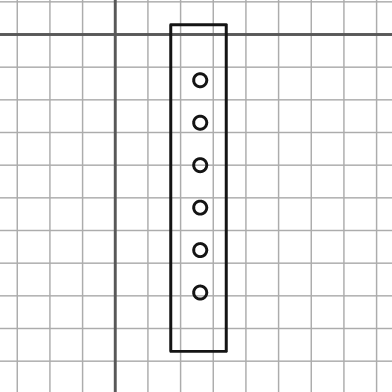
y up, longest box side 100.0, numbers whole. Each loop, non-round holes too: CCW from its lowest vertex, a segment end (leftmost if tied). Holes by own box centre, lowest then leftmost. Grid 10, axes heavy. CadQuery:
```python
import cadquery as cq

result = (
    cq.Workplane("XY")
    .moveTo(17.0, -97.0)
    .lineTo(34.0, -97.0)
    .lineTo(34.0, 3.0)
    .lineTo(17.0, 3.0)
    .close()
    .moveTo(26.0, -79.0)
    .circle(2.0)
    .moveTo(26.0, -66.0)
    .circle(2.0)
    .moveTo(26.0, -53.0)
    .circle(2.0)
    .moveTo(26.0, -40.0)
    .circle(2.0)
    .moveTo(26.0, -27.0)
    .circle(2.0)
    .moveTo(26.0, -14.0)
    .circle(2.0)
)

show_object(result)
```